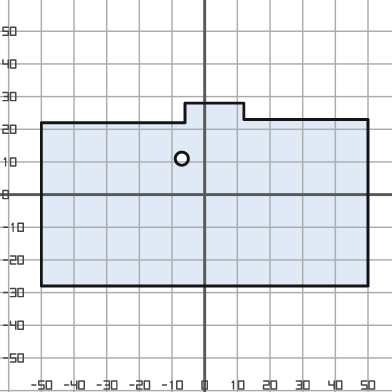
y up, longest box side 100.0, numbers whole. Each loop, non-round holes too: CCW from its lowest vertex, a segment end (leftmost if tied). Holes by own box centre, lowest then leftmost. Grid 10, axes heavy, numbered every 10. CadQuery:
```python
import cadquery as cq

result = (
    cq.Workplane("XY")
    .moveTo(-50.0, -28.0)
    .lineTo(50.0, -28.0)
    .lineTo(50.0, 23.0)
    .lineTo(12.0, 23.0)
    .lineTo(12.0, 28.0)
    .lineTo(-6.0, 28.0)
    .lineTo(-6.0, 22.0)
    .lineTo(-50.0, 22.0)
    .close()
    .moveTo(-7.0, 11.0)
    .circle(2.0)
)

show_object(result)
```